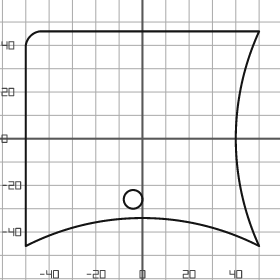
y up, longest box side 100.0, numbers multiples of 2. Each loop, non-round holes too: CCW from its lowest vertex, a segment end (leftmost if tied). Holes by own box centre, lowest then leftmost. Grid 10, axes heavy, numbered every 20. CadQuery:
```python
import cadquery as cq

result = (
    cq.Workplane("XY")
    .moveTo(-50.0, -46.0)
    .threePointArc((0.0, -34.0), (50.0, -46.0))
    .threePointArc((40.0, 0.0), (50.0, 46.0))
    .lineTo(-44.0, 46.0)
    .threePointArc((-48.0, 44.0), (-50.0, 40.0))
    .close()
    .moveTo(-4.0, -26.0)
    .circle(4.0)
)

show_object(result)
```